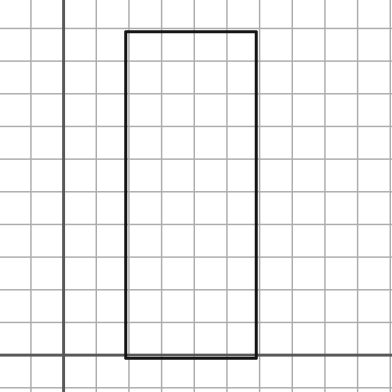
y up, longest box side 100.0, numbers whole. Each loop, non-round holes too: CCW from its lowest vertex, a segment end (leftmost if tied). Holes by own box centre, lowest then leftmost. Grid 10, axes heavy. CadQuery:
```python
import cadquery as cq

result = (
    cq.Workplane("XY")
    .moveTo(19.0, -1.0)
    .lineTo(59.0, -1.0)
    .lineTo(59.0, 99.0)
    .lineTo(19.0, 99.0)
    .close()
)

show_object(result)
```